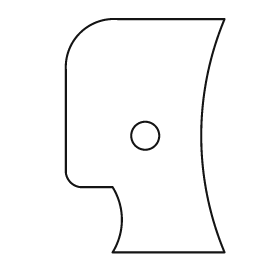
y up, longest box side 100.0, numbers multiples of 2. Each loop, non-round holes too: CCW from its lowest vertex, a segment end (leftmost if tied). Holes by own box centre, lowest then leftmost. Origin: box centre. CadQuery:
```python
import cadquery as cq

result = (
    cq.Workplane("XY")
    .moveTo(-14.0, -50.0)
    .lineTo(34.0, -50.0)
    .threePointArc((24.0, 0.0), (34.0, 50.0))
    .lineTo(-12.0, 50.0)
    .threePointArc((-28.0, 44.0), (-34.0, 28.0))
    .lineTo(-34.0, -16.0)
    .threePointArc((-32.0, -20.0), (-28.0, -22.0))
    .lineTo(-14.0, -22.0)
    .threePointArc((-10.0, -36.0), (-14.0, -50.0))
    .close()
    .moveTo(0.0, 0.0)
    .circle(6.0)
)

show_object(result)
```